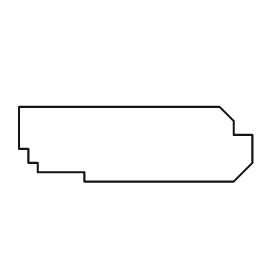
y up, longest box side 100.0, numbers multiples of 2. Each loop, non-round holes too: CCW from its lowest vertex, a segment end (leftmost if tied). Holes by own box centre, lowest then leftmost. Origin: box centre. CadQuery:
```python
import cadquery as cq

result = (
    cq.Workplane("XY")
    .moveTo(-22.0, -16.0)
    .lineTo(42.0, -16.0)
    .lineTo(50.0, -8.0)
    .lineTo(50.0, 4.0)
    .lineTo(42.0, 4.0)
    .lineTo(42.0, 10.0)
    .lineTo(36.0, 16.0)
    .lineTo(-50.0, 16.0)
    .lineTo(-50.0, -2.0)
    .lineTo(-46.0, -2.0)
    .lineTo(-46.0, -8.0)
    .lineTo(-42.0, -8.0)
    .lineTo(-42.0, -12.0)
    .lineTo(-22.0, -12.0)
    .close()
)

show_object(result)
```